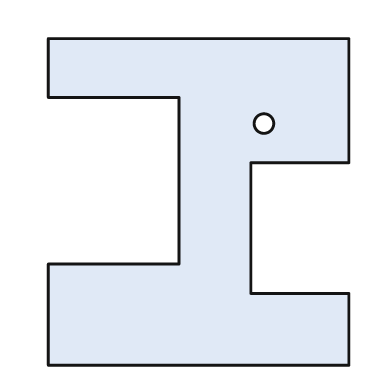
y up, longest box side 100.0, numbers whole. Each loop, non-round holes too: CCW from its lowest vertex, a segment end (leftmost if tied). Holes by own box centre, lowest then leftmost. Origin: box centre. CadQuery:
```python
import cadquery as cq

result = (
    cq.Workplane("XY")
    .moveTo(-46.0, -50.0)
    .lineTo(46.0, -50.0)
    .lineTo(46.0, -28.0)
    .lineTo(16.0, -28.0)
    .lineTo(16.0, 12.0)
    .lineTo(46.0, 12.0)
    .lineTo(46.0, 50.0)
    .lineTo(-46.0, 50.0)
    .lineTo(-46.0, 32.0)
    .lineTo(-6.0, 32.0)
    .lineTo(-6.0, -19.0)
    .lineTo(-46.0, -19.0)
    .close()
    .moveTo(20.0, 24.0)
    .circle(3.0)
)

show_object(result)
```